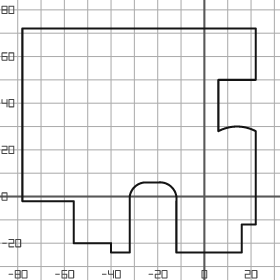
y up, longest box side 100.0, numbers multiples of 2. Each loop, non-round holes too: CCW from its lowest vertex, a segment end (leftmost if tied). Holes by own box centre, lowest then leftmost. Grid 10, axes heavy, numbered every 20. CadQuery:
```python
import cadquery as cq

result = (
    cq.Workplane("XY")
    .moveTo(-40.0, -24.0)
    .lineTo(-32.0, -24.0)
    .lineTo(-32.0, 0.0)
    .threePointArc((-30.0, 4.0), (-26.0, 6.0))
    .lineTo(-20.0, 6.0)
    .threePointArc((-14.0, 4.0), (-12.0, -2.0))
    .lineTo(-12.0, -24.0)
    .lineTo(16.0, -24.0)
    .lineTo(16.0, -12.0)
    .lineTo(22.0, -12.0)
    .lineTo(22.0, 28.0)
    .threePointArc((14.0, 30.0), (6.0, 28.0))
    .lineTo(6.0, 50.0)
    .lineTo(22.0, 50.0)
    .lineTo(22.0, 72.0)
    .lineTo(-78.0, 72.0)
    .lineTo(-78.0, -2.0)
    .lineTo(-56.0, -2.0)
    .lineTo(-56.0, -20.0)
    .lineTo(-40.0, -20.0)
    .close()
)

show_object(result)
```